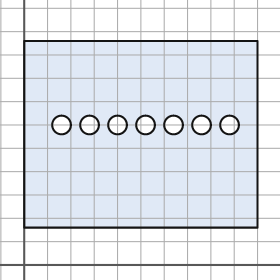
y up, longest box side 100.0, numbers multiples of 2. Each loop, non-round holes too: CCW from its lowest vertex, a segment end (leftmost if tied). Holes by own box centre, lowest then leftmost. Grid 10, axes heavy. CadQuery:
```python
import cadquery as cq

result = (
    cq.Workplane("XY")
    .moveTo(0.0, 16.0)
    .lineTo(100.0, 16.0)
    .lineTo(100.0, 96.0)
    .lineTo(0.0, 96.0)
    .close()
    .moveTo(16.0, 60.0)
    .circle(4.0)
    .moveTo(28.0, 60.0)
    .circle(4.0)
    .moveTo(40.0, 60.0)
    .circle(4.0)
    .moveTo(52.0, 60.0)
    .circle(4.0)
    .moveTo(64.0, 60.0)
    .circle(4.0)
    .moveTo(76.0, 60.0)
    .circle(4.0)
    .moveTo(88.0, 60.0)
    .circle(4.0)
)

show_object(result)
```